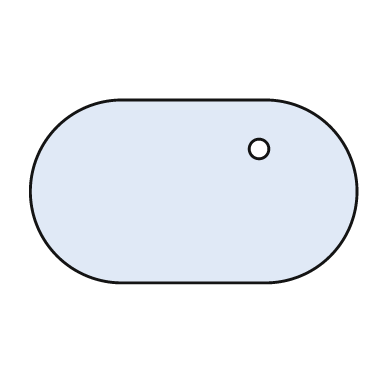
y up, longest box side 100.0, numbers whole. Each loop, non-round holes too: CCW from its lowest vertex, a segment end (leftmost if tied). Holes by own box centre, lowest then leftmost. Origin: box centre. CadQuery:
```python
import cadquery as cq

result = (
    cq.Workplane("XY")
    .moveTo(-22.0, -28.0)
    .lineTo(22.0, -28.0)
    .threePointArc((50.0, 0.0), (22.0, 28.0))
    .lineTo(-22.0, 28.0)
    .threePointArc((-50.0, 0.0), (-22.0, -28.0))
    .close()
    .moveTo(20.0, 13.0)
    .circle(3.0)
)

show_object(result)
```